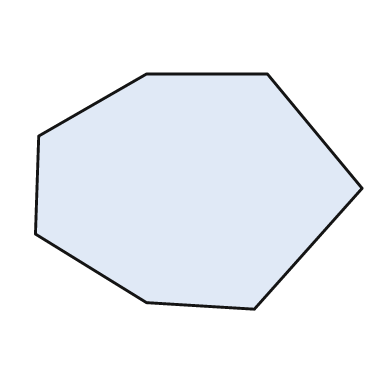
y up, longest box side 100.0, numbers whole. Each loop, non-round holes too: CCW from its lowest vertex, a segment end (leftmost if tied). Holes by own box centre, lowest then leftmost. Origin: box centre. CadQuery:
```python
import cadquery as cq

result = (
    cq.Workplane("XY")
    .moveTo(17.0, -36.0)
    .lineTo(50.0, 1.0)
    .lineTo(21.0, 36.0)
    .lineTo(-16.0, 36.0)
    .lineTo(-49.0, 17.0)
    .lineTo(-50.0, -13.0)
    .lineTo(-16.0, -34.0)
    .close()
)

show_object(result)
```